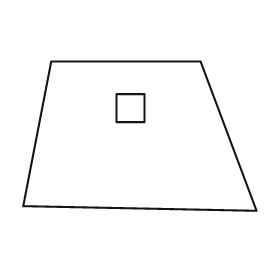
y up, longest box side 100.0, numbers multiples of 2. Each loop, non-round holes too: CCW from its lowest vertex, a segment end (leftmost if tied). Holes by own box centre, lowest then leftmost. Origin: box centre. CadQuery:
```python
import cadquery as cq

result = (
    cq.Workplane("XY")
    .moveTo(50.0, -32.0)
    .lineTo(26.0, 32.0)
    .lineTo(-38.0, 32.0)
    .lineTo(-50.0, -30.0)
    .close()
    .moveTo(-10.0, 6.0)
    .lineTo(2.0, 6.0)
    .lineTo(2.0, 18.0)
    .lineTo(-10.0, 18.0)
    .close()
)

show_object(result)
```